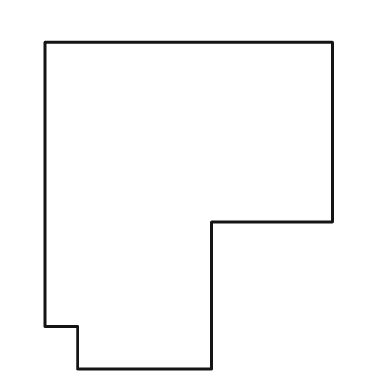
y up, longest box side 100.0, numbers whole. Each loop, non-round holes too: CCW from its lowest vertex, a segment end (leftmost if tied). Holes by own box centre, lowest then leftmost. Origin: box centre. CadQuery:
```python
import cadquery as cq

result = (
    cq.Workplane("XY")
    .moveTo(-34.0, -50.0)
    .lineTo(7.0, -50.0)
    .lineTo(7.0, -5.0)
    .lineTo(44.0, -5.0)
    .lineTo(44.0, 50.0)
    .lineTo(-44.0, 50.0)
    .lineTo(-44.0, -37.0)
    .lineTo(-34.0, -37.0)
    .close()
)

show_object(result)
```